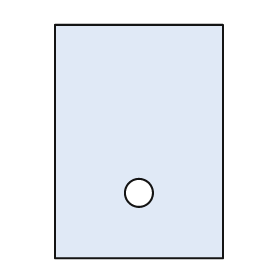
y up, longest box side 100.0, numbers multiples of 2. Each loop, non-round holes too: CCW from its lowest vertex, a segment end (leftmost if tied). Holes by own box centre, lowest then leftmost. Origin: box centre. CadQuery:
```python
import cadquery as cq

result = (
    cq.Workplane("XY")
    .moveTo(-36.0, -50.0)
    .lineTo(36.0, -50.0)
    .lineTo(36.0, 50.0)
    .lineTo(-36.0, 50.0)
    .close()
    .moveTo(0.0, -22.0)
    .circle(6.0)
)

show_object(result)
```